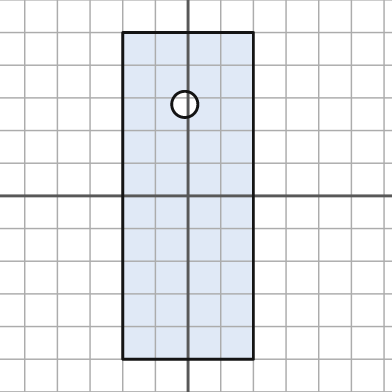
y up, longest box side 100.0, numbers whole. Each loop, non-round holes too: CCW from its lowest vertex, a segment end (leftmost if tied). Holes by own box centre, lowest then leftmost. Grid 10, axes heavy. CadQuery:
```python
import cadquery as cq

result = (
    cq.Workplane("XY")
    .moveTo(-20.0, -50.0)
    .lineTo(20.0, -50.0)
    .lineTo(20.0, 50.0)
    .lineTo(-20.0, 50.0)
    .close()
    .moveTo(-1.0, 28.0)
    .circle(4.0)
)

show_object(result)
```